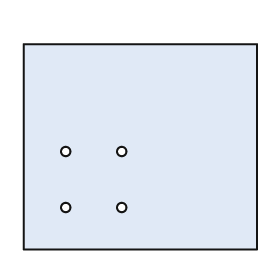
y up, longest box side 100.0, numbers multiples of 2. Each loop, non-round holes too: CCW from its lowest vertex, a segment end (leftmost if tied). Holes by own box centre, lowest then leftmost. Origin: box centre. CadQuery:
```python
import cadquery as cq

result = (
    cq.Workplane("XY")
    .moveTo(-50.0, -44.0)
    .lineTo(50.0, -44.0)
    .lineTo(50.0, 44.0)
    .lineTo(-50.0, 44.0)
    .close()
    .moveTo(-32.0, -26.0)
    .circle(2.0)
    .moveTo(-8.0, -26.0)
    .circle(2.0)
    .moveTo(-32.0, -2.0)
    .circle(2.0)
    .moveTo(-8.0, -2.0)
    .circle(2.0)
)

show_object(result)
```